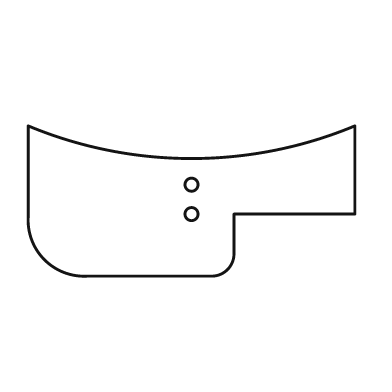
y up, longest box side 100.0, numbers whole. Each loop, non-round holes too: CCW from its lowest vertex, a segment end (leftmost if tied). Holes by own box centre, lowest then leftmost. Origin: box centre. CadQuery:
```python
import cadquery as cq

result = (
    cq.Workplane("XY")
    .moveTo(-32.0, -23.0)
    .lineTo(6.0, -23.0)
    .threePointArc((11.0, -21.0), (13.0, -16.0))
    .lineTo(13.0, -4.0)
    .lineTo(50.0, -4.0)
    .lineTo(50.0, 23.0)
    .threePointArc((0.0, 13.0), (-50.0, 23.0))
    .lineTo(-50.0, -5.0)
    .threePointArc((-45.0, -18.0), (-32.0, -23.0))
    .close()
    .moveTo(0.0, -4.0)
    .circle(2.0)
    .moveTo(0.0, 5.0)
    .circle(2.0)
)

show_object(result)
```